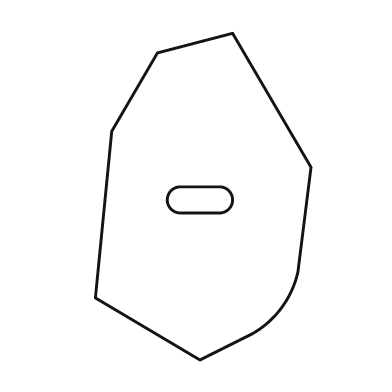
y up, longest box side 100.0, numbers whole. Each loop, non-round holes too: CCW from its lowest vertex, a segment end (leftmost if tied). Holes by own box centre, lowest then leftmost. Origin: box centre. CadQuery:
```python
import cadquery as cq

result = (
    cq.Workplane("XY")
    .moveTo(-1.0, -50.0)
    .lineTo(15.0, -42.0)
    .threePointArc((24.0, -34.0), (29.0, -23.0))
    .lineTo(33.0, 9.0)
    .lineTo(9.0, 50.0)
    .lineTo(-14.0, 44.0)
    .lineTo(-28.0, 20.0)
    .lineTo(-33.0, -31.0)
    .close()
    .moveTo(-7.0, -5.0)
    .lineTo(5.0, -5.0)
    .threePointArc((9.0, -1.0), (5.0, 3.0))
    .lineTo(-7.0, 3.0)
    .threePointArc((-11.0, -1.0), (-7.0, -5.0))
    .close()
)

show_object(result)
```